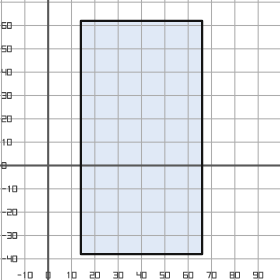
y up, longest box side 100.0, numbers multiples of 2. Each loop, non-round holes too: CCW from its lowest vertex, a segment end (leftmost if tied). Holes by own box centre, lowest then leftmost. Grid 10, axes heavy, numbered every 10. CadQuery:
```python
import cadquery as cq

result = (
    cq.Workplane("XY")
    .moveTo(14.0, -38.0)
    .lineTo(66.0, -38.0)
    .lineTo(66.0, 62.0)
    .lineTo(14.0, 62.0)
    .close()
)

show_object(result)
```